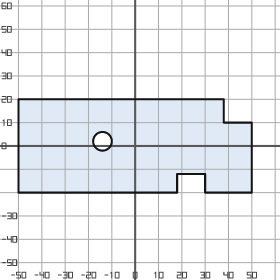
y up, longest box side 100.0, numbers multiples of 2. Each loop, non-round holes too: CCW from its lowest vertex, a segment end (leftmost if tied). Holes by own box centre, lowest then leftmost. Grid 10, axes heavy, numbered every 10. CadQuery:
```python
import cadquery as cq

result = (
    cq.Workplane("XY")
    .moveTo(-50.0, -20.0)
    .lineTo(18.0, -20.0)
    .lineTo(18.0, -12.0)
    .lineTo(30.0, -12.0)
    .lineTo(30.0, -20.0)
    .lineTo(50.0, -20.0)
    .lineTo(50.0, 10.0)
    .lineTo(38.0, 10.0)
    .lineTo(38.0, 20.0)
    .lineTo(-50.0, 20.0)
    .close()
    .moveTo(-14.0, 2.0)
    .circle(4.0)
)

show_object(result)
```